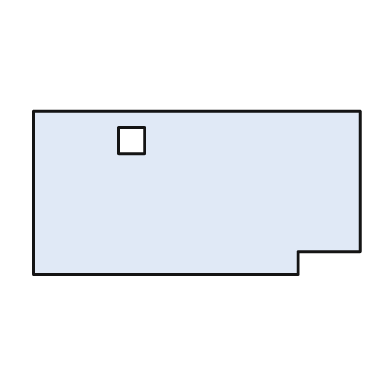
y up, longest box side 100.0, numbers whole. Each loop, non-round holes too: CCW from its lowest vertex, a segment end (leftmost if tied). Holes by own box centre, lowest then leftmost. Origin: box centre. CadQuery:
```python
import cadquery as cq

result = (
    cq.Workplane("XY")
    .moveTo(-50.0, -25.0)
    .lineTo(31.0, -25.0)
    .lineTo(31.0, -18.0)
    .lineTo(50.0, -18.0)
    .lineTo(50.0, 25.0)
    .lineTo(-50.0, 25.0)
    .close()
    .moveTo(-24.0, 12.0)
    .lineTo(-16.0, 12.0)
    .lineTo(-16.0, 20.0)
    .lineTo(-24.0, 20.0)
    .close()
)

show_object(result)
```